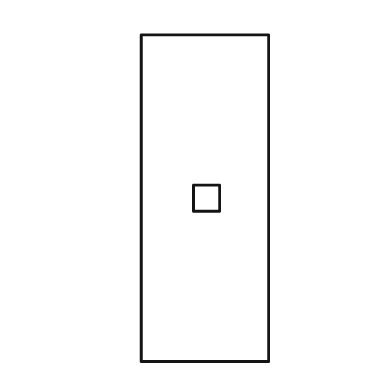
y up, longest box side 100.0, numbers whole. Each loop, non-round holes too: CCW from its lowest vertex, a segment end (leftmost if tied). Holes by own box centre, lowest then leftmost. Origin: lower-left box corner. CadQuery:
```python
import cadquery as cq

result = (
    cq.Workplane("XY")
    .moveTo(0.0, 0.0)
    .lineTo(39.0, 0.0)
    .lineTo(39.0, 100.0)
    .lineTo(0.0, 100.0)
    .close()
    .moveTo(16.0, 46.0)
    .lineTo(24.0, 46.0)
    .lineTo(24.0, 54.0)
    .lineTo(16.0, 54.0)
    .close()
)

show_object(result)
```